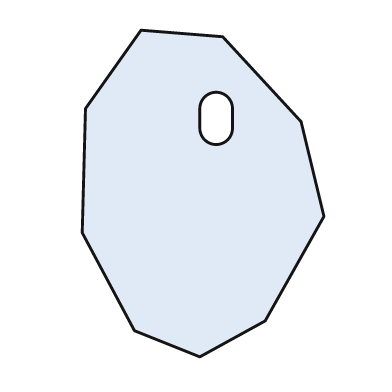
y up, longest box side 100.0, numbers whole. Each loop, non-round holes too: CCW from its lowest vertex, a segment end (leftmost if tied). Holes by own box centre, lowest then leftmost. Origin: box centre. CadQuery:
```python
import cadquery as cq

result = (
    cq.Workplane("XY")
    .moveTo(-1.0, -50.0)
    .lineTo(19.0, -39.0)
    .lineTo(37.0, -7.0)
    .lineTo(30.0, 22.0)
    .lineTo(6.0, 48.0)
    .lineTo(-19.0, 50.0)
    .lineTo(-36.0, 26.0)
    .lineTo(-37.0, -12.0)
    .lineTo(-21.0, -42.0)
    .close()
    .moveTo(-1.0, 20.0)
    .threePointArc((4.0, 15.0), (9.0, 20.0))
    .lineTo(9.0, 26.0)
    .threePointArc((4.0, 31.0), (-1.0, 26.0))
    .close()
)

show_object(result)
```